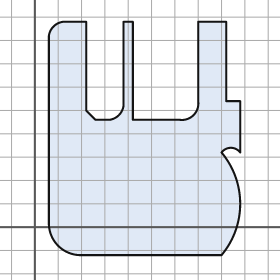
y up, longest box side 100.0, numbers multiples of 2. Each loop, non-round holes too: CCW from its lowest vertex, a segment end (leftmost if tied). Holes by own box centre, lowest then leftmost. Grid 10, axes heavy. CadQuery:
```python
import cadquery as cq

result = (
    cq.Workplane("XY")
    .moveTo(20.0, -12.0)
    .lineTo(80.0, -12.0)
    .threePointArc((88.0, 10.0), (80.0, 32.0))
    .threePointArc((84.0, 34.0), (88.0, 32.0))
    .lineTo(88.0, 54.0)
    .lineTo(82.0, 54.0)
    .lineTo(82.0, 88.0)
    .lineTo(70.0, 88.0)
    .lineTo(70.0, 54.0)
    .threePointArc((68.0, 48.0), (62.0, 46.0))
    .lineTo(42.0, 46.0)
    .lineTo(42.0, 88.0)
    .lineTo(38.0, 88.0)
    .lineTo(38.0, 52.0)
    .threePointArc((36.0, 48.0), (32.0, 46.0))
    .lineTo(26.0, 46.0)
    .lineTo(22.0, 50.0)
    .lineTo(22.0, 88.0)
    .lineTo(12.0, 88.0)
    .threePointArc((8.0, 86.0), (6.0, 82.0))
    .lineTo(6.0, 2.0)
    .threePointArc((10.0, -8.0), (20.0, -12.0))
    .close()
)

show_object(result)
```